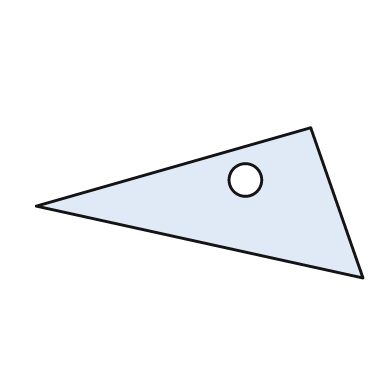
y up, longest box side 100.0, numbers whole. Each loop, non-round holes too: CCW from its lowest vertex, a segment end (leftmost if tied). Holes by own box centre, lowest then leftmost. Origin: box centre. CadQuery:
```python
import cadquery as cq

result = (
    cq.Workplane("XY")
    .moveTo(50.0, -23.0)
    .lineTo(34.0, 23.0)
    .lineTo(-50.0, -1.0)
    .close()
    .moveTo(14.0, 7.0)
    .circle(5.0)
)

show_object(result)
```